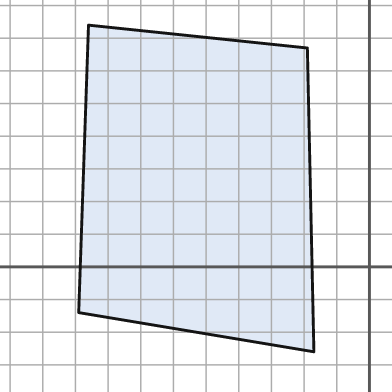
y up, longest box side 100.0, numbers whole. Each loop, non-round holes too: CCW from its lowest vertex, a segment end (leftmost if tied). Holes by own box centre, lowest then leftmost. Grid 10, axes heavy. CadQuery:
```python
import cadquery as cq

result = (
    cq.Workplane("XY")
    .moveTo(-17.0, -26.0)
    .lineTo(-19.0, 67.0)
    .lineTo(-86.0, 74.0)
    .lineTo(-89.0, -14.0)
    .close()
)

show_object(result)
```